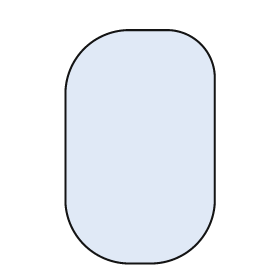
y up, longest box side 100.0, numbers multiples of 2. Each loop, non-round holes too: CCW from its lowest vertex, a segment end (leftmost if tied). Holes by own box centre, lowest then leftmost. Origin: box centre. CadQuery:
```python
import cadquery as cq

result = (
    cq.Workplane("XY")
    .moveTo(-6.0, -50.0)
    .lineTo(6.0, -50.0)
    .threePointArc((24.0, -42.0), (32.0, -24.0))
    .lineTo(32.0, 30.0)
    .threePointArc((26.0, 44.0), (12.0, 50.0))
    .lineTo(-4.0, 50.0)
    .threePointArc((-24.0, 42.0), (-32.0, 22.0))
    .lineTo(-32.0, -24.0)
    .threePointArc((-24.0, -42.0), (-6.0, -50.0))
    .close()
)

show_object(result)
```